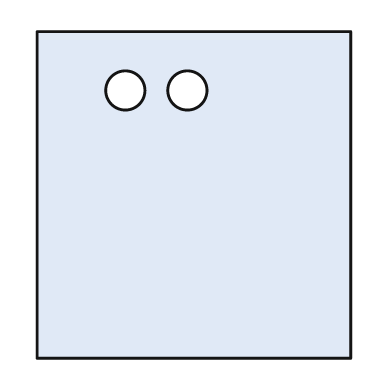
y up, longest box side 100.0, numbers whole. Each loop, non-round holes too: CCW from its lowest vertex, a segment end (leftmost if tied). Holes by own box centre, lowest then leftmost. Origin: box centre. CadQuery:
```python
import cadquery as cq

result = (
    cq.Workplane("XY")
    .moveTo(-48.0, -50.0)
    .lineTo(48.0, -50.0)
    .lineTo(48.0, 50.0)
    .lineTo(-48.0, 50.0)
    .close()
    .moveTo(-21.0, 32.0)
    .circle(6.0)
    .moveTo(-2.0, 32.0)
    .circle(6.0)
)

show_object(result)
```